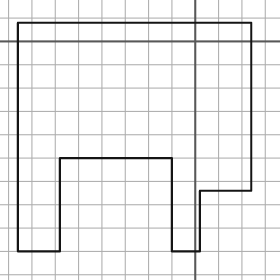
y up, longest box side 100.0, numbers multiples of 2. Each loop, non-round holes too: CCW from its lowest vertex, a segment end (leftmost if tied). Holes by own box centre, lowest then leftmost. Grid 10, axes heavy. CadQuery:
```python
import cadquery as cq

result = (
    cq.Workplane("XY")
    .moveTo(-76.0, -90.0)
    .lineTo(-58.0, -90.0)
    .lineTo(-58.0, -50.0)
    .lineTo(-10.0, -50.0)
    .lineTo(-10.0, -90.0)
    .lineTo(2.0, -90.0)
    .lineTo(2.0, -64.0)
    .lineTo(24.0, -64.0)
    .lineTo(24.0, 8.0)
    .lineTo(-76.0, 8.0)
    .close()
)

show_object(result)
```